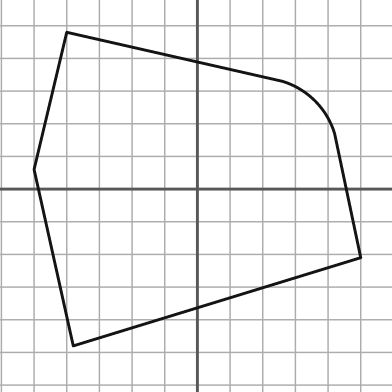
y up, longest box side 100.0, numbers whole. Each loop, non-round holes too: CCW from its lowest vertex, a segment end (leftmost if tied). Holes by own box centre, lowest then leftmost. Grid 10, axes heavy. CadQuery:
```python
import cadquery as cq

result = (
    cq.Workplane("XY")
    .moveTo(-38.0, -48.0)
    .lineTo(50.0, -21.0)
    .lineTo(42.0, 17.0)
    .threePointArc((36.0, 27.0), (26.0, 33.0))
    .lineTo(-40.0, 48.0)
    .lineTo(-50.0, 6.0)
    .close()
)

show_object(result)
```